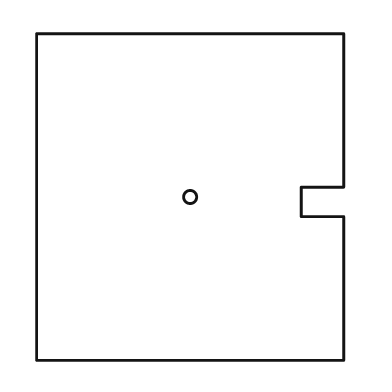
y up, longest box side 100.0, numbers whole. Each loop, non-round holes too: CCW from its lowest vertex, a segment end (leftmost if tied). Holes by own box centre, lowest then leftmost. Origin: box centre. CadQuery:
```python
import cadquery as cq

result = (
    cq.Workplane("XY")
    .moveTo(-47.0, -50.0)
    .lineTo(47.0, -50.0)
    .lineTo(47.0, -6.0)
    .lineTo(34.0, -6.0)
    .lineTo(34.0, 3.0)
    .lineTo(47.0, 3.0)
    .lineTo(47.0, 50.0)
    .lineTo(-47.0, 50.0)
    .close()
    .moveTo(0.0, 0.0)
    .circle(2.0)
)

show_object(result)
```